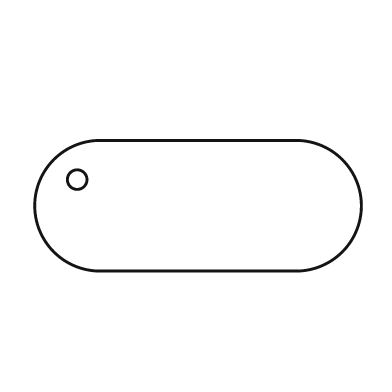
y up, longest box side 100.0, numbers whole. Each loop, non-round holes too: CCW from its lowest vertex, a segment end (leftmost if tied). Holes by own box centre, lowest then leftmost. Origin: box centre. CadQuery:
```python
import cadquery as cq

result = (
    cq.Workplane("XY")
    .moveTo(-30.0, -20.0)
    .lineTo(30.0, -20.0)
    .threePointArc((50.0, 0.0), (30.0, 20.0))
    .lineTo(-30.0, 20.0)
    .threePointArc((-50.0, 0.0), (-30.0, -20.0))
    .close()
    .moveTo(-37.0, 8.0)
    .circle(3.0)
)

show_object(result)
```